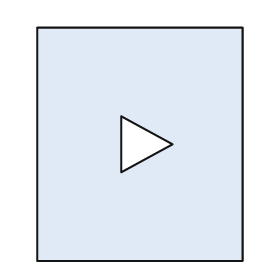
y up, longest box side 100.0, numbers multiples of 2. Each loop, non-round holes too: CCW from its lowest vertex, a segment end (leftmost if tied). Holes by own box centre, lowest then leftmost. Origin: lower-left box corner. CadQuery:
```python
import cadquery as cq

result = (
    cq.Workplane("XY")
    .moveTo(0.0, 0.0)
    .lineTo(88.0, 0.0)
    .lineTo(88.0, 100.0)
    .lineTo(0.0, 100.0)
    .close()
    .moveTo(36.0, 38.0)
    .lineTo(58.0, 50.0)
    .lineTo(36.0, 62.0)
    .close()
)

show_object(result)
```